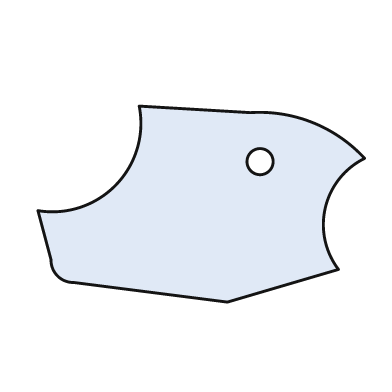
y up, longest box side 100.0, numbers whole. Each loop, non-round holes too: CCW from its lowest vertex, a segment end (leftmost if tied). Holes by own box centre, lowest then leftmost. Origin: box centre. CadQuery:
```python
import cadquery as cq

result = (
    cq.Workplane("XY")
    .moveTo(8.0, -30.0)
    .lineTo(42.0, -20.0)
    .threePointArc((38.0, -1.0), (50.0, 14.0))
    .threePointArc((34.0, 25.0), (15.0, 28.0))
    .lineTo(-19.0, 30.0)
    .threePointArc((-26.0, 6.0), (-50.0, -2.0))
    .lineTo(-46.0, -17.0)
    .threePointArc((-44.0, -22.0), (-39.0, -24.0))
    .close()
    .moveTo(18.0, 13.0)
    .circle(4.0)
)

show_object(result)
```